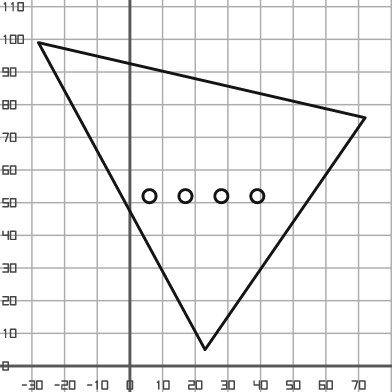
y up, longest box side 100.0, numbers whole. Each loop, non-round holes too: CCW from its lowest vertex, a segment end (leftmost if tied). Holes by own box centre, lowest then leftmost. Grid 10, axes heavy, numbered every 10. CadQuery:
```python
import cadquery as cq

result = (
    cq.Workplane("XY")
    .moveTo(23.0, 5.0)
    .lineTo(72.0, 76.0)
    .lineTo(-28.0, 99.0)
    .close()
    .moveTo(6.0, 52.0)
    .circle(2.0)
    .moveTo(17.0, 52.0)
    .circle(2.0)
    .moveTo(28.0, 52.0)
    .circle(2.0)
    .moveTo(39.0, 52.0)
    .circle(2.0)
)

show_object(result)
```